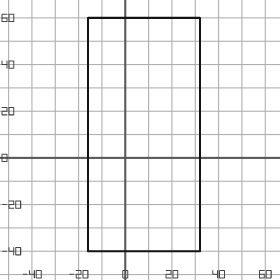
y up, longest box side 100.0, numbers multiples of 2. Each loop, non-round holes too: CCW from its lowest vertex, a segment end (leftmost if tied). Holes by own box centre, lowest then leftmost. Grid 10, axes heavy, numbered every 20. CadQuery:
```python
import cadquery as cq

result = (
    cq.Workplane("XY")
    .moveTo(-16.0, -40.0)
    .lineTo(32.0, -40.0)
    .lineTo(32.0, 60.0)
    .lineTo(-16.0, 60.0)
    .close()
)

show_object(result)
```